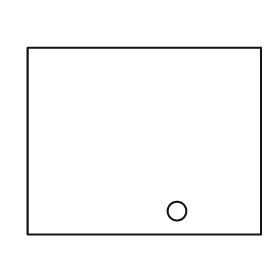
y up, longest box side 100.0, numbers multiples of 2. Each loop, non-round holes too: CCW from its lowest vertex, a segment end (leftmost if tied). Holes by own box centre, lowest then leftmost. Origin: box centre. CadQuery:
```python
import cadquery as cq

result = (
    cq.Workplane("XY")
    .moveTo(-50.0, -40.0)
    .lineTo(50.0, -40.0)
    .lineTo(50.0, 40.0)
    .lineTo(-50.0, 40.0)
    .close()
    .moveTo(14.0, -30.0)
    .circle(4.0)
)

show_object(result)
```